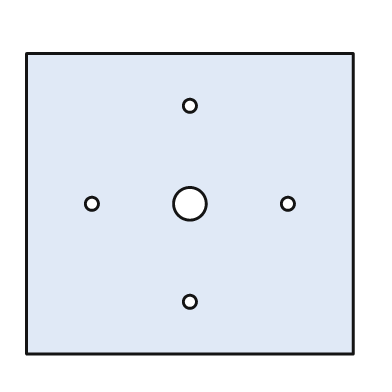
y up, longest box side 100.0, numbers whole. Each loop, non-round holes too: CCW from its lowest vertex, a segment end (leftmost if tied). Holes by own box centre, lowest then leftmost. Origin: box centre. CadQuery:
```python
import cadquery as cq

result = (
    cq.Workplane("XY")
    .moveTo(-50.0, -46.0)
    .lineTo(50.0, -46.0)
    .lineTo(50.0, 46.0)
    .lineTo(-50.0, 46.0)
    .close()
    .moveTo(0.0, -30.0)
    .circle(2.0)
    .moveTo(-30.0, 0.0)
    .circle(2.0)
    .moveTo(0.0, 0.0)
    .circle(5.0)
    .moveTo(30.0, 0.0)
    .circle(2.0)
    .moveTo(0.0, 30.0)
    .circle(2.0)
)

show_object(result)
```